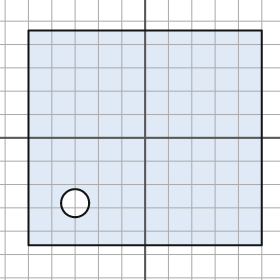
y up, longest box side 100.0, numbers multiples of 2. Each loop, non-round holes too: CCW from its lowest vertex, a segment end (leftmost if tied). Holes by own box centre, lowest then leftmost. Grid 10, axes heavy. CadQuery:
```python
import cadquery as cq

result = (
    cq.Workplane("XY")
    .moveTo(-50.0, -46.0)
    .lineTo(50.0, -46.0)
    .lineTo(50.0, 46.0)
    .lineTo(-50.0, 46.0)
    .close()
    .moveTo(-30.0, -28.0)
    .circle(6.0)
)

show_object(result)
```